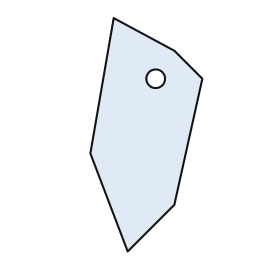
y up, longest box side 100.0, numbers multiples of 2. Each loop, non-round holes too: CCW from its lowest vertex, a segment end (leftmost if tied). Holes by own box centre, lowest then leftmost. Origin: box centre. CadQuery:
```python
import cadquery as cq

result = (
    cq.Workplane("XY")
    .moveTo(-8.0, -50.0)
    .lineTo(12.0, -30.0)
    .lineTo(24.0, 24.0)
    .lineTo(12.0, 36.0)
    .lineTo(-14.0, 50.0)
    .lineTo(-24.0, -8.0)
    .close()
    .moveTo(4.0, 24.0)
    .circle(4.0)
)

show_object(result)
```